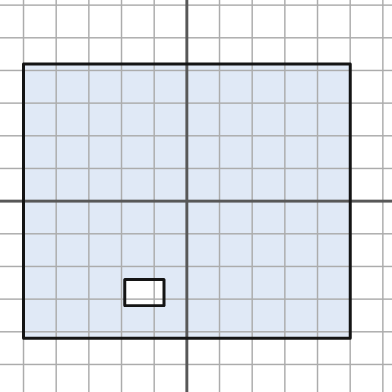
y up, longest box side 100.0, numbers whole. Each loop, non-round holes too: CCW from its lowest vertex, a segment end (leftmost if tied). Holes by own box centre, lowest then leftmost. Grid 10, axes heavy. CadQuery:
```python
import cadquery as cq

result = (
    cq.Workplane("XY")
    .moveTo(-50.0, -42.0)
    .lineTo(50.0, -42.0)
    .lineTo(50.0, 42.0)
    .lineTo(-50.0, 42.0)
    .close()
    .moveTo(-19.0, -32.0)
    .lineTo(-7.0, -32.0)
    .lineTo(-7.0, -24.0)
    .lineTo(-19.0, -24.0)
    .close()
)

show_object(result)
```